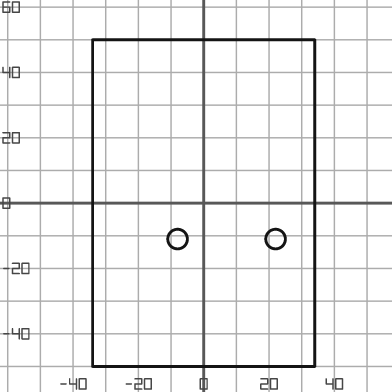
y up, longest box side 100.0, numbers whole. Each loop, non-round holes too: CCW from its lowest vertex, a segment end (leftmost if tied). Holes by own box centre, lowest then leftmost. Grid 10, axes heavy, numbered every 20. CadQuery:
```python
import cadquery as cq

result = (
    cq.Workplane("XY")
    .moveTo(-34.0, -50.0)
    .lineTo(34.0, -50.0)
    .lineTo(34.0, 50.0)
    .lineTo(-34.0, 50.0)
    .close()
    .moveTo(-8.0, -11.0)
    .circle(3.0)
    .moveTo(22.0, -11.0)
    .circle(3.0)
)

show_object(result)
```